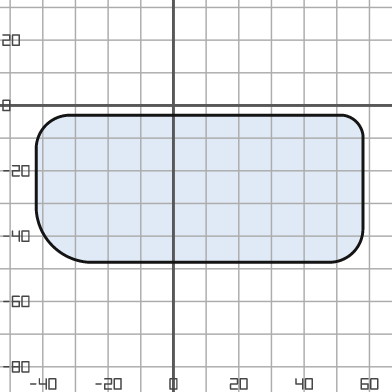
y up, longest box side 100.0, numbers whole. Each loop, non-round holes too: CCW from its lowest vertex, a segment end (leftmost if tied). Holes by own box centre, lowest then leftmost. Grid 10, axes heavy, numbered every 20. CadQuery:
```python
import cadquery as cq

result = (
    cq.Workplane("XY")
    .moveTo(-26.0, -48.0)
    .lineTo(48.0, -48.0)
    .threePointArc((55.0, -45.0), (58.0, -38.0))
    .lineTo(58.0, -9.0)
    .threePointArc((56.0, -5.0), (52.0, -3.0))
    .lineTo(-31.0, -3.0)
    .threePointArc((-39.0, -6.0), (-42.0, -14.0))
    .lineTo(-42.0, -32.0)
    .threePointArc((-37.0, -43.0), (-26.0, -48.0))
    .close()
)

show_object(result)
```